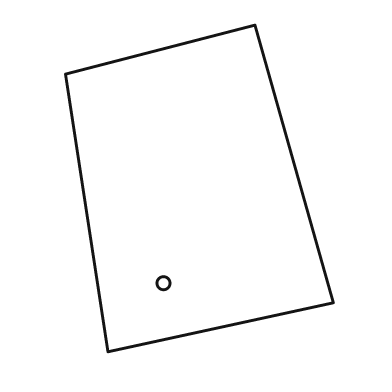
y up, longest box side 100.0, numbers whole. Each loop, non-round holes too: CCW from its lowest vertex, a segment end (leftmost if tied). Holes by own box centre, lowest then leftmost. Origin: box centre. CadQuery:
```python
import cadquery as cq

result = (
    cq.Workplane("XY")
    .moveTo(-28.0, -50.0)
    .lineTo(41.0, -35.0)
    .lineTo(17.0, 50.0)
    .lineTo(-41.0, 35.0)
    .close()
    .moveTo(-11.0, -29.0)
    .circle(2.0)
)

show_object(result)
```